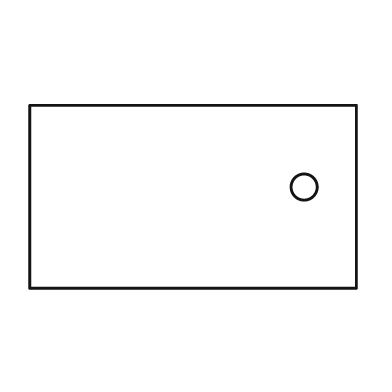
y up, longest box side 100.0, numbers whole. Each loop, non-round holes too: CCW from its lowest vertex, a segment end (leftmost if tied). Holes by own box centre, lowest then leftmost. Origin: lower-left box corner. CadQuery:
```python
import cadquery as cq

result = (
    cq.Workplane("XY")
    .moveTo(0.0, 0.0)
    .lineTo(100.0, 0.0)
    .lineTo(100.0, 56.0)
    .lineTo(0.0, 56.0)
    .close()
    .moveTo(84.0, 31.0)
    .circle(4.0)
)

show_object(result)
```